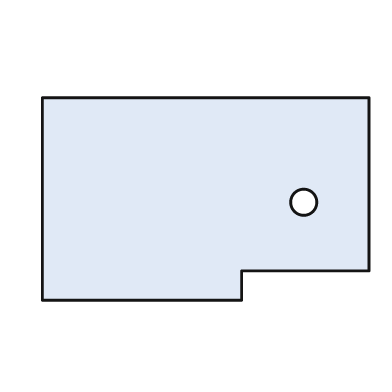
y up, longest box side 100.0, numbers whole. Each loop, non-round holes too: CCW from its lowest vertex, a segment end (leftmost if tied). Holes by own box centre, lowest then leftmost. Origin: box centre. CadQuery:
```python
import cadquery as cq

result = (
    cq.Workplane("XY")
    .moveTo(-50.0, -31.0)
    .lineTo(11.0, -31.0)
    .lineTo(11.0, -22.0)
    .lineTo(50.0, -22.0)
    .lineTo(50.0, 31.0)
    .lineTo(-50.0, 31.0)
    .close()
    .moveTo(30.0, -1.0)
    .circle(4.0)
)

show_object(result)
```